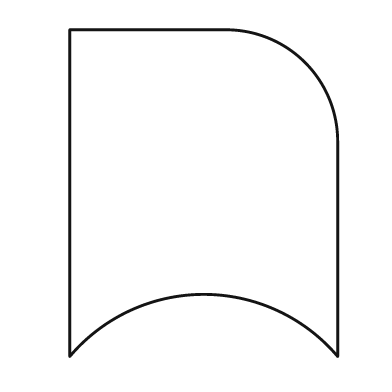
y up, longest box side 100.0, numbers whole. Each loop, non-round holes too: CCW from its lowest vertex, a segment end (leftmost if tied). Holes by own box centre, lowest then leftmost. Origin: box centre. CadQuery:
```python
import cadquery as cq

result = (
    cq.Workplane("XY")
    .moveTo(-41.0, -50.0)
    .threePointArc((0.0, -31.0), (41.0, -50.0))
    .lineTo(41.0, 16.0)
    .threePointArc((31.0, 40.0), (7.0, 50.0))
    .lineTo(-41.0, 50.0)
    .close()
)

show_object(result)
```